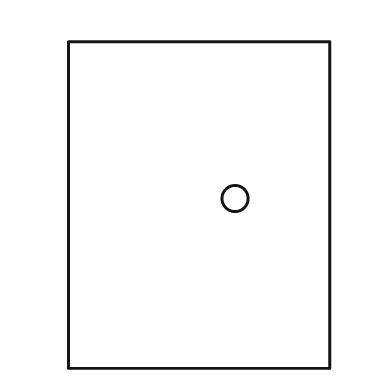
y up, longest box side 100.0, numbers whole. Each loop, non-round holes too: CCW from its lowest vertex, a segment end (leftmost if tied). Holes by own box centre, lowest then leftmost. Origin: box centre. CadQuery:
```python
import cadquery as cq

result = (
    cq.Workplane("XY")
    .moveTo(-40.0, -50.0)
    .lineTo(40.0, -50.0)
    .lineTo(40.0, 50.0)
    .lineTo(-40.0, 50.0)
    .close()
    .moveTo(11.0, 2.0)
    .circle(4.0)
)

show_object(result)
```